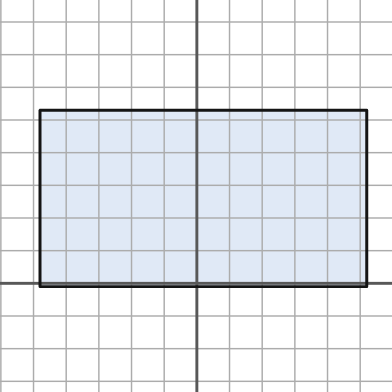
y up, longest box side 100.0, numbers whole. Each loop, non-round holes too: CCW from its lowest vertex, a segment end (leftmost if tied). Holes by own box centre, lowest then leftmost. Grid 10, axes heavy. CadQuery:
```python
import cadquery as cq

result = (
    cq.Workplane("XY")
    .moveTo(-48.0, -1.0)
    .lineTo(52.0, -1.0)
    .lineTo(52.0, 53.0)
    .lineTo(-48.0, 53.0)
    .close()
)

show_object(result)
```